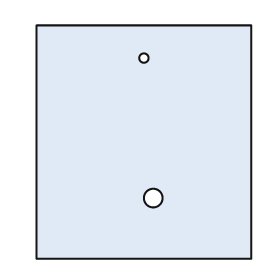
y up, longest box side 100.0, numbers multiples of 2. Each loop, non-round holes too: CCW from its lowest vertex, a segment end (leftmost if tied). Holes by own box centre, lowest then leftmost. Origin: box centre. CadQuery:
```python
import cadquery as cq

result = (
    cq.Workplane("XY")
    .moveTo(-46.0, -50.0)
    .lineTo(46.0, -50.0)
    .lineTo(46.0, 50.0)
    .lineTo(-46.0, 50.0)
    .close()
    .moveTo(4.0, -24.0)
    .circle(4.0)
    .moveTo(0.0, 36.0)
    .circle(2.0)
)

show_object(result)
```